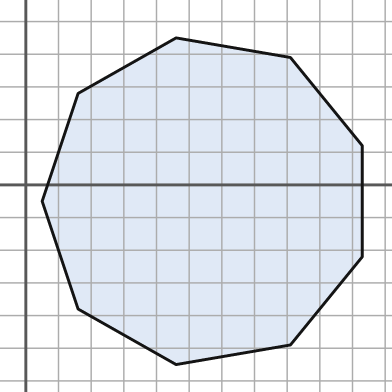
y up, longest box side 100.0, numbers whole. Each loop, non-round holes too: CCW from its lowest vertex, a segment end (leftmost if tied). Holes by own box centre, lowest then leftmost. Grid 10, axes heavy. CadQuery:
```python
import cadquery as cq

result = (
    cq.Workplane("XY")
    .moveTo(46.0, -55.0)
    .lineTo(81.0, -49.0)
    .lineTo(103.0, -22.0)
    .lineTo(103.0, 12.0)
    .lineTo(81.0, 39.0)
    .lineTo(46.0, 45.0)
    .lineTo(16.0, 28.0)
    .lineTo(5.0, -5.0)
    .lineTo(16.0, -38.0)
    .close()
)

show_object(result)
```